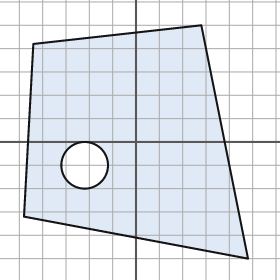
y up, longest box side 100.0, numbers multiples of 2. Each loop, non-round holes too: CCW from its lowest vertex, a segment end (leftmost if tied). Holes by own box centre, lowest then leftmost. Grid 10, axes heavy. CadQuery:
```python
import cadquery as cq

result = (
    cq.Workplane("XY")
    .moveTo(48.0, -50.0)
    .lineTo(28.0, 50.0)
    .lineTo(-44.0, 42.0)
    .lineTo(-48.0, -32.0)
    .close()
    .moveTo(-22.0, -10.0)
    .circle(10.0)
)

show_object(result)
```